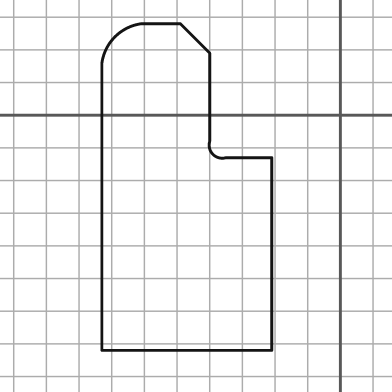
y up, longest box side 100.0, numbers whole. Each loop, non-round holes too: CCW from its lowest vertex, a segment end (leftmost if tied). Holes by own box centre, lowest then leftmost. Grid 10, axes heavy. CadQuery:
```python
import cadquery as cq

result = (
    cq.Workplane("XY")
    .moveTo(-73.0, -72.0)
    .lineTo(-21.0, -72.0)
    .lineTo(-21.0, -13.0)
    .lineTo(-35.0, -13.0)
    .threePointArc((-39.0, -12.0), (-40.0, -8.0))
    .lineTo(-40.0, 19.0)
    .lineTo(-49.0, 28.0)
    .lineTo(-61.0, 28.0)
    .threePointArc((-69.0, 24.0), (-73.0, 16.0))
    .close()
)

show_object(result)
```